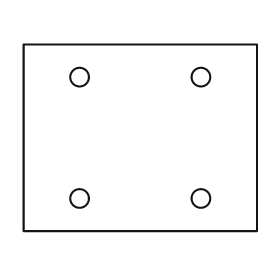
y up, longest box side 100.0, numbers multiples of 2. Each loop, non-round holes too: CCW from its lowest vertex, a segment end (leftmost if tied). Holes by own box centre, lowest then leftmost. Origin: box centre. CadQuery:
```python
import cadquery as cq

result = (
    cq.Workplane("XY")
    .moveTo(-50.0, -40.0)
    .lineTo(50.0, -40.0)
    .lineTo(50.0, 40.0)
    .lineTo(-50.0, 40.0)
    .close()
    .moveTo(-26.0, -26.0)
    .circle(4.0)
    .moveTo(26.0, -26.0)
    .circle(4.0)
    .moveTo(-26.0, 26.0)
    .circle(4.0)
    .moveTo(26.0, 26.0)
    .circle(4.0)
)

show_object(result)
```